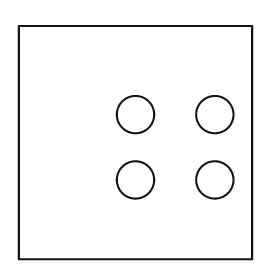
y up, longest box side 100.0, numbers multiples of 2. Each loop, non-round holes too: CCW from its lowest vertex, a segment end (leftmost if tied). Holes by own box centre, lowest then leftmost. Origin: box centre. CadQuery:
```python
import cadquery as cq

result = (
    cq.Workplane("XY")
    .moveTo(-50.0, -50.0)
    .lineTo(50.0, -50.0)
    .lineTo(50.0, 50.0)
    .lineTo(-50.0, 50.0)
    .close()
    .moveTo(0.0, -16.0)
    .circle(8.0)
    .moveTo(34.0, -16.0)
    .circle(8.0)
    .moveTo(0.0, 12.0)
    .circle(8.0)
    .moveTo(34.0, 12.0)
    .circle(8.0)
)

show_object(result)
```